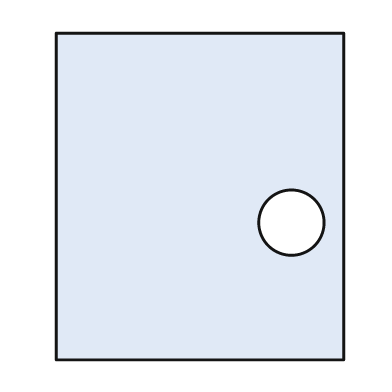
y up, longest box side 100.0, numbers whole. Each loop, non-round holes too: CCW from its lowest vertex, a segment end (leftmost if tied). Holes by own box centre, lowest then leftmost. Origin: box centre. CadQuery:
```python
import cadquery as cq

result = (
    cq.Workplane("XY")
    .moveTo(-44.0, -50.0)
    .lineTo(44.0, -50.0)
    .lineTo(44.0, 50.0)
    .lineTo(-44.0, 50.0)
    .close()
    .moveTo(28.0, -8.0)
    .circle(10.0)
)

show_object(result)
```